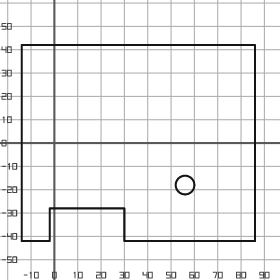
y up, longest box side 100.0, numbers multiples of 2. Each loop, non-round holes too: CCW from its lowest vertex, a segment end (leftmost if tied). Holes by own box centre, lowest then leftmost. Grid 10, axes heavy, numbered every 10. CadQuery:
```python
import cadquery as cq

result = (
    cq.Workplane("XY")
    .moveTo(-14.0, -42.0)
    .lineTo(-2.0, -42.0)
    .lineTo(-2.0, -28.0)
    .lineTo(30.0, -28.0)
    .lineTo(30.0, -42.0)
    .lineTo(86.0, -42.0)
    .lineTo(86.0, 42.0)
    .lineTo(-14.0, 42.0)
    .close()
    .moveTo(56.0, -18.0)
    .circle(4.0)
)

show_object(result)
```